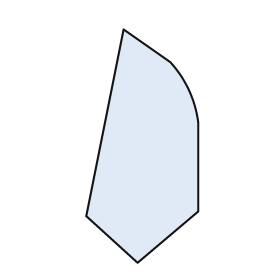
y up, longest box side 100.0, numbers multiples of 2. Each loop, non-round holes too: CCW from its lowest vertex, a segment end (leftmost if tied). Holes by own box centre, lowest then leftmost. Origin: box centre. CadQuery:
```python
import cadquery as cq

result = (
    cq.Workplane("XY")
    .moveTo(-2.0, -50.0)
    .lineTo(24.0, -28.0)
    .lineTo(24.0, 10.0)
    .threePointArc((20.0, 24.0), (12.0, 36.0))
    .lineTo(-8.0, 50.0)
    .lineTo(-24.0, -30.0)
    .close()
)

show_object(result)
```